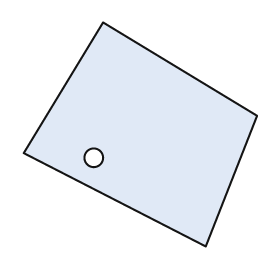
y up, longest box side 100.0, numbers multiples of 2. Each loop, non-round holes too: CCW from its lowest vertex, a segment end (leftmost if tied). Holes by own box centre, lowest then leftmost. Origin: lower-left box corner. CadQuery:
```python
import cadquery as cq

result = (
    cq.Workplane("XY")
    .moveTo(78.0, 0.0)
    .lineTo(100.0, 56.0)
    .lineTo(34.0, 96.0)
    .lineTo(0.0, 40.0)
    .close()
    .moveTo(30.0, 38.0)
    .circle(4.0)
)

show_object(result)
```